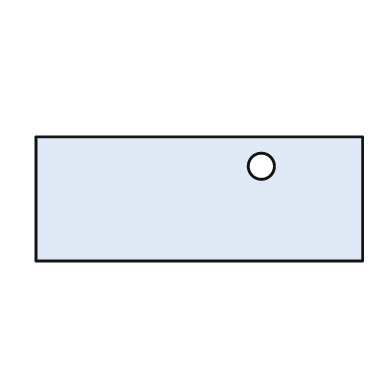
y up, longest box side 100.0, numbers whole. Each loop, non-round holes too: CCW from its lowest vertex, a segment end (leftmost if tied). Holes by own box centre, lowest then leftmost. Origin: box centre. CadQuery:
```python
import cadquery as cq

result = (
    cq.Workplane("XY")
    .moveTo(-50.0, -19.0)
    .lineTo(50.0, -19.0)
    .lineTo(50.0, 19.0)
    .lineTo(-50.0, 19.0)
    .close()
    .moveTo(19.0, 10.0)
    .circle(4.0)
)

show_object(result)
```